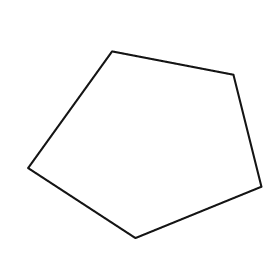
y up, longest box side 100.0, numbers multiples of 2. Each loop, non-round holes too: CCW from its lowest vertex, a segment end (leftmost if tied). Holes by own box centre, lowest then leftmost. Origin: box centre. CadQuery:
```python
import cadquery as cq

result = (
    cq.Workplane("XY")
    .moveTo(-4.0, -40.0)
    .lineTo(50.0, -18.0)
    .lineTo(38.0, 30.0)
    .lineTo(-14.0, 40.0)
    .lineTo(-50.0, -10.0)
    .close()
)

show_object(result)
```